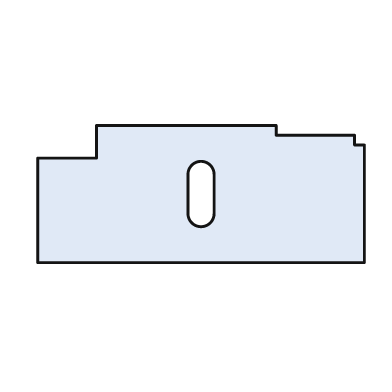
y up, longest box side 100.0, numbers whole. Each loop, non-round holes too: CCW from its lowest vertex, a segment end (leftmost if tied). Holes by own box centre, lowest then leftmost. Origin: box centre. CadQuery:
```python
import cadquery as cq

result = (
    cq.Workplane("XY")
    .moveTo(-50.0, -21.0)
    .lineTo(50.0, -21.0)
    .lineTo(50.0, 15.0)
    .lineTo(47.0, 15.0)
    .lineTo(47.0, 18.0)
    .lineTo(23.0, 18.0)
    .lineTo(23.0, 21.0)
    .lineTo(-32.0, 21.0)
    .lineTo(-32.0, 11.0)
    .lineTo(-50.0, 11.0)
    .close()
    .moveTo(-4.0, -6.0)
    .threePointArc((0.0, -10.0), (4.0, -6.0))
    .lineTo(4.0, 6.0)
    .threePointArc((0.0, 10.0), (-4.0, 6.0))
    .close()
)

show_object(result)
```